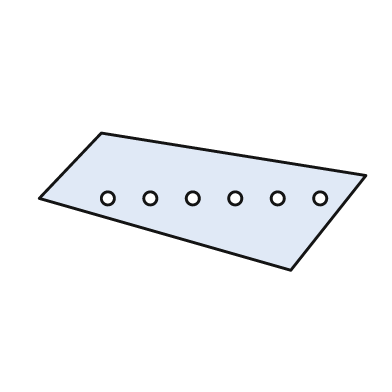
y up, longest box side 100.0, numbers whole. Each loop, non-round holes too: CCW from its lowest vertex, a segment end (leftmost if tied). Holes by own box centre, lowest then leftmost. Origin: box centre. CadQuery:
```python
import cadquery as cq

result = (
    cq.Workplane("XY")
    .moveTo(27.0, -21.0)
    .lineTo(50.0, 8.0)
    .lineTo(-31.0, 21.0)
    .lineTo(-50.0, 1.0)
    .close()
    .moveTo(-29.0, 1.0)
    .circle(2.0)
    .moveTo(-16.0, 1.0)
    .circle(2.0)
    .moveTo(-3.0, 1.0)
    .circle(2.0)
    .moveTo(10.0, 1.0)
    .circle(2.0)
    .moveTo(23.0, 1.0)
    .circle(2.0)
    .moveTo(36.0, 1.0)
    .circle(2.0)
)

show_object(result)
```